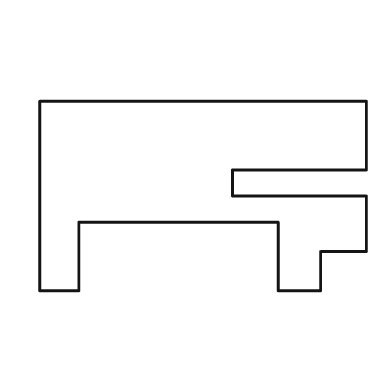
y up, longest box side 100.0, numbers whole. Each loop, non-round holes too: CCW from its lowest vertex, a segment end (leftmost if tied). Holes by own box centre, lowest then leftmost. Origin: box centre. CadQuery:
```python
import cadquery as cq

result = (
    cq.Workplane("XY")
    .moveTo(-50.0, -29.0)
    .lineTo(-38.0, -29.0)
    .lineTo(-38.0, -8.0)
    .lineTo(23.0, -8.0)
    .lineTo(23.0, -29.0)
    .lineTo(36.0, -29.0)
    .lineTo(36.0, -17.0)
    .lineTo(50.0, -17.0)
    .lineTo(50.0, 0.0)
    .lineTo(9.0, 0.0)
    .lineTo(9.0, 8.0)
    .lineTo(50.0, 8.0)
    .lineTo(50.0, 29.0)
    .lineTo(-50.0, 29.0)
    .close()
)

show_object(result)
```